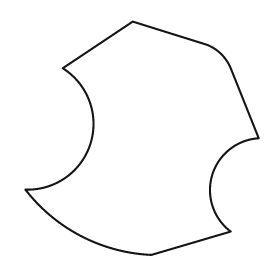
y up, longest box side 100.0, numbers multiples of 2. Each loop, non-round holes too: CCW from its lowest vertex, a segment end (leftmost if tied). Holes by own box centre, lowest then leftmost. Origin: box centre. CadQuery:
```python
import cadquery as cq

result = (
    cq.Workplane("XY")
    .moveTo(4.0, -50.0)
    .lineTo(38.0, -40.0)
    .threePointArc((30.0, -16.0), (50.0, 0.0))
    .lineTo(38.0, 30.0)
    .threePointArc((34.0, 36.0), (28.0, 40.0))
    .lineTo(-4.0, 50.0)
    .lineTo(-34.0, 30.0)
    .threePointArc((-22.0, -2.0), (-50.0, -22.0))
    .threePointArc((-26.0, -42.0), (4.0, -50.0))
    .close()
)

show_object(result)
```